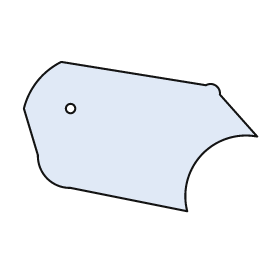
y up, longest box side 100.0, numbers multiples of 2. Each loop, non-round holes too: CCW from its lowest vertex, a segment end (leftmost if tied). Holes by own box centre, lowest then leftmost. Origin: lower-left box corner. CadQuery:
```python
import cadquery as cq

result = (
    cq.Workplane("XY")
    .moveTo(70.0, 0.0)
    .threePointArc((76.0, 24.0), (100.0, 32.0))
    .lineTo(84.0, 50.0)
    .threePointArc((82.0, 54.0), (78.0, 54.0))
    .lineTo(16.0, 64.0)
    .threePointArc((6.0, 56.0), (0.0, 44.0))
    .lineTo(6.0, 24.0)
    .threePointArc((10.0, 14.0), (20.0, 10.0))
    .close()
    .moveTo(20.0, 44.0)
    .circle(2.0)
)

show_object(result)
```